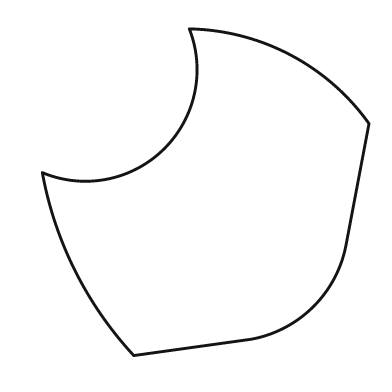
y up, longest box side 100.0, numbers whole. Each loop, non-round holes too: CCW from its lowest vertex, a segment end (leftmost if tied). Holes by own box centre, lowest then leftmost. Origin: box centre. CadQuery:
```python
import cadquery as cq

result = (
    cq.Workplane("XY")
    .moveTo(-22.0, -50.0)
    .lineTo(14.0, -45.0)
    .threePointArc((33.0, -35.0), (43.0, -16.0))
    .lineTo(50.0, 21.0)
    .threePointArc((26.0, 42.0), (-5.0, 50.0))
    .threePointArc((-13.0, 13.0), (-50.0, 6.0))
    .threePointArc((-40.0, -24.0), (-22.0, -50.0))
    .close()
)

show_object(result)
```